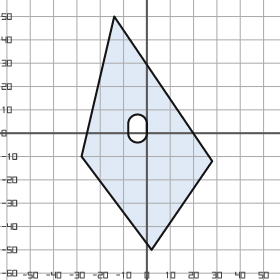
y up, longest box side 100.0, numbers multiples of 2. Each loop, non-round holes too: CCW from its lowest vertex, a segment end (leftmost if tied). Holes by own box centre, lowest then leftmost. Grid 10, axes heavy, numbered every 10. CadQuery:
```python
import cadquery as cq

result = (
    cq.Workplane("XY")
    .moveTo(2.0, -50.0)
    .lineTo(28.0, -12.0)
    .lineTo(-14.0, 50.0)
    .lineTo(-28.0, -10.0)
    .close()
    .moveTo(-8.0, 0.0)
    .threePointArc((-4.0, -4.0), (0.0, 0.0))
    .lineTo(0.0, 4.0)
    .threePointArc((-4.0, 8.0), (-8.0, 4.0))
    .close()
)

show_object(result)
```